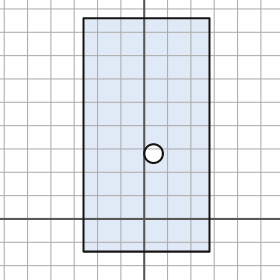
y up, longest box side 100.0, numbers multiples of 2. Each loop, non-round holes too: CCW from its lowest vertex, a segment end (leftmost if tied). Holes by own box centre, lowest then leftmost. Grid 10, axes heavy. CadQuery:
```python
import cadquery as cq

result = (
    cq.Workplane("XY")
    .moveTo(-26.0, -14.0)
    .lineTo(28.0, -14.0)
    .lineTo(28.0, 86.0)
    .lineTo(-26.0, 86.0)
    .close()
    .moveTo(4.0, 28.0)
    .circle(4.0)
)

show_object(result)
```